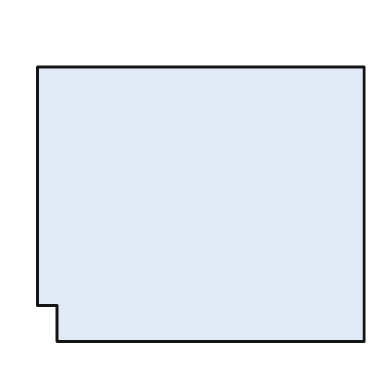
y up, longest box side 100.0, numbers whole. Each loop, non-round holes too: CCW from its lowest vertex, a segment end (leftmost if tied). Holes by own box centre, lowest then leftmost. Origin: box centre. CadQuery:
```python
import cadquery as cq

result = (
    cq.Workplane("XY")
    .moveTo(-44.0, -42.0)
    .lineTo(50.0, -42.0)
    .lineTo(50.0, 42.0)
    .lineTo(-50.0, 42.0)
    .lineTo(-50.0, -31.0)
    .lineTo(-44.0, -31.0)
    .close()
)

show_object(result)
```